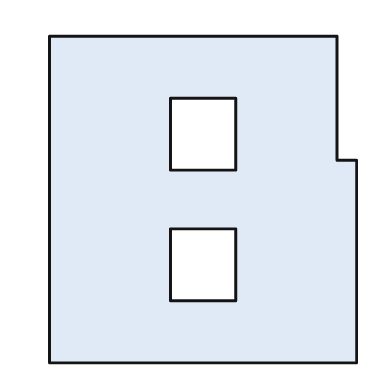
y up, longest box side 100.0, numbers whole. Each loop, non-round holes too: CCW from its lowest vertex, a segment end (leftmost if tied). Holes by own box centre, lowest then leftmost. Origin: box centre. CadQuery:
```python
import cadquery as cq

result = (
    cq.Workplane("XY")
    .moveTo(-47.0, -50.0)
    .lineTo(47.0, -50.0)
    .lineTo(47.0, 12.0)
    .lineTo(41.0, 12.0)
    .lineTo(41.0, 50.0)
    .lineTo(-47.0, 50.0)
    .close()
    .moveTo(-10.0, -31.0)
    .lineTo(10.0, -31.0)
    .lineTo(10.0, -9.0)
    .lineTo(-10.0, -9.0)
    .close()
    .moveTo(-10.0, 9.0)
    .lineTo(10.0, 9.0)
    .lineTo(10.0, 31.0)
    .lineTo(-10.0, 31.0)
    .close()
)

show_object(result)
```